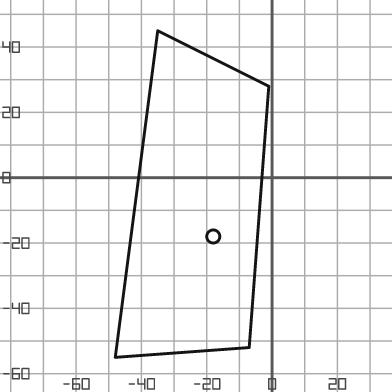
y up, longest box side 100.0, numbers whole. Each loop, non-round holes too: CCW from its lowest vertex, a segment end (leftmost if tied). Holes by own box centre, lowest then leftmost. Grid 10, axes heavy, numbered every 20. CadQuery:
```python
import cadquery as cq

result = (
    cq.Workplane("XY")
    .moveTo(-48.0, -55.0)
    .lineTo(-7.0, -52.0)
    .lineTo(-1.0, 28.0)
    .lineTo(-35.0, 45.0)
    .close()
    .moveTo(-18.0, -18.0)
    .circle(2.0)
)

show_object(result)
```